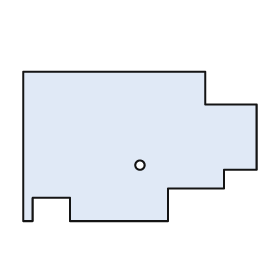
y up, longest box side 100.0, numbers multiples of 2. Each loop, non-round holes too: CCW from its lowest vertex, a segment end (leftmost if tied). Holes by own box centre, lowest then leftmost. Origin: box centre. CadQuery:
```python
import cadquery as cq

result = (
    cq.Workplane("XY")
    .moveTo(-50.0, -32.0)
    .lineTo(-46.0, -32.0)
    .lineTo(-46.0, -22.0)
    .lineTo(-30.0, -22.0)
    .lineTo(-30.0, -32.0)
    .lineTo(12.0, -32.0)
    .lineTo(12.0, -18.0)
    .lineTo(36.0, -18.0)
    .lineTo(36.0, -10.0)
    .lineTo(50.0, -10.0)
    .lineTo(50.0, 18.0)
    .lineTo(28.0, 18.0)
    .lineTo(28.0, 32.0)
    .lineTo(-50.0, 32.0)
    .close()
    .moveTo(0.0, -8.0)
    .circle(2.0)
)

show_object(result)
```